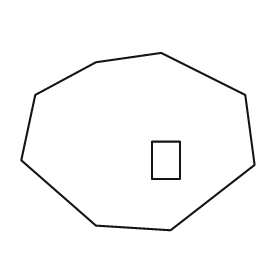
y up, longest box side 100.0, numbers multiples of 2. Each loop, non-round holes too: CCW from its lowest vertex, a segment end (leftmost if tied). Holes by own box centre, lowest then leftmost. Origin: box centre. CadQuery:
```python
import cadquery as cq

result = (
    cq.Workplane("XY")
    .moveTo(14.0, -38.0)
    .lineTo(50.0, -10.0)
    .lineTo(46.0, 20.0)
    .lineTo(10.0, 38.0)
    .lineTo(-18.0, 34.0)
    .lineTo(-44.0, 20.0)
    .lineTo(-50.0, -8.0)
    .lineTo(-18.0, -36.0)
    .close()
    .moveTo(6.0, -16.0)
    .lineTo(18.0, -16.0)
    .lineTo(18.0, 0.0)
    .lineTo(6.0, 0.0)
    .close()
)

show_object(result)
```